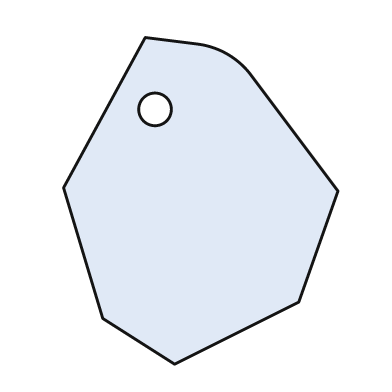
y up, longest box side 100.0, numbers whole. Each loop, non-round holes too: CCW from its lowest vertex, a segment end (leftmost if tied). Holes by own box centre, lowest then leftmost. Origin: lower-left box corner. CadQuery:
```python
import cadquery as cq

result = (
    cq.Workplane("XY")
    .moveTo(34.0, 0.0)
    .lineTo(72.0, 19.0)
    .lineTo(84.0, 53.0)
    .lineTo(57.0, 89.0)
    .threePointArc((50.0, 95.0), (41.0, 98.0))
    .lineTo(25.0, 100.0)
    .lineTo(0.0, 54.0)
    .lineTo(12.0, 14.0)
    .close()
    .moveTo(28.0, 78.0)
    .circle(5.0)
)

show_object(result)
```